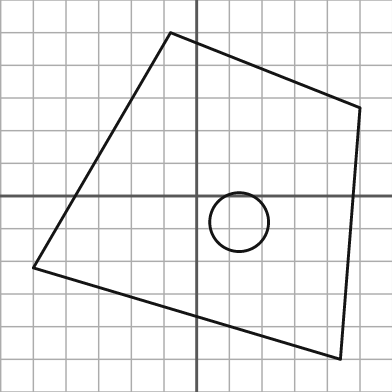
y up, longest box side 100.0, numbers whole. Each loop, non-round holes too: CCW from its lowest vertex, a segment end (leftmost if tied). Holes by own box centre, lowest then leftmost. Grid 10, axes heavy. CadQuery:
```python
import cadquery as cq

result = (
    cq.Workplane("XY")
    .moveTo(44.0, -50.0)
    .lineTo(50.0, 27.0)
    .lineTo(-8.0, 50.0)
    .lineTo(-50.0, -22.0)
    .close()
    .moveTo(13.0, -8.0)
    .circle(9.0)
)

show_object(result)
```